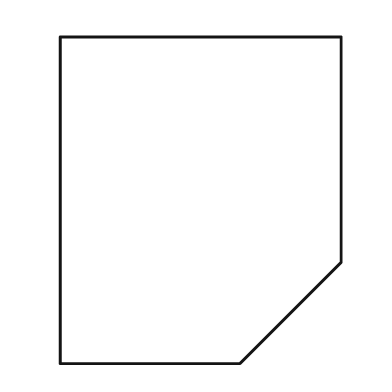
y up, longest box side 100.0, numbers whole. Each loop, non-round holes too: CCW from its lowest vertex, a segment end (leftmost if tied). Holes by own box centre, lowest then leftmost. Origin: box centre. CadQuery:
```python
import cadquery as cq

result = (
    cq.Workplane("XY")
    .moveTo(-43.0, -50.0)
    .lineTo(12.0, -50.0)
    .lineTo(43.0, -19.0)
    .lineTo(43.0, 50.0)
    .lineTo(-43.0, 50.0)
    .close()
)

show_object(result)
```